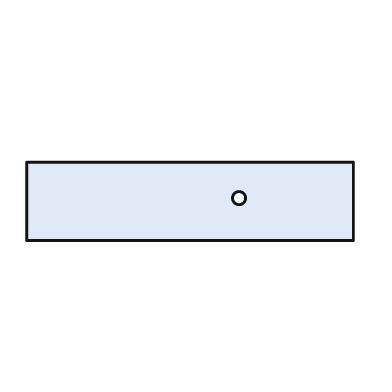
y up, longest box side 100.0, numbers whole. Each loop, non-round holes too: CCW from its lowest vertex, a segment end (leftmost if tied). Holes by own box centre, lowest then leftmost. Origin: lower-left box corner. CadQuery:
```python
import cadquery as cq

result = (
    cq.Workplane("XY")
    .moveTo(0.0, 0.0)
    .lineTo(100.0, 0.0)
    .lineTo(100.0, 24.0)
    .lineTo(0.0, 24.0)
    .close()
    .moveTo(65.0, 13.0)
    .circle(2.0)
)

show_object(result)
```